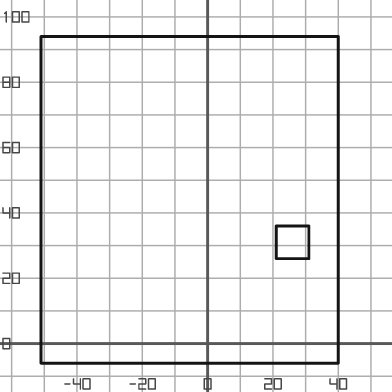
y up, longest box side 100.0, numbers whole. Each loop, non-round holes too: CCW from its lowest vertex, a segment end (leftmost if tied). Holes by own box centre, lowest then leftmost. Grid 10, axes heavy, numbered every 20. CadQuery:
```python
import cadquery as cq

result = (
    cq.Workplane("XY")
    .moveTo(-51.0, -6.0)
    .lineTo(40.0, -6.0)
    .lineTo(40.0, 94.0)
    .lineTo(-51.0, 94.0)
    .close()
    .moveTo(21.0, 26.0)
    .lineTo(31.0, 26.0)
    .lineTo(31.0, 36.0)
    .lineTo(21.0, 36.0)
    .close()
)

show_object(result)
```